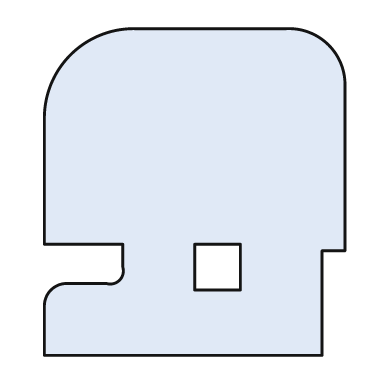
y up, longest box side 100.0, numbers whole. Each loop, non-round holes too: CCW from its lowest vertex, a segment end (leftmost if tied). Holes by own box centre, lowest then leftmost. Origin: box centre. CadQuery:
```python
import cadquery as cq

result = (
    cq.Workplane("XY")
    .moveTo(-46.0, -50.0)
    .lineTo(39.0, -50.0)
    .lineTo(39.0, -18.0)
    .lineTo(46.0, -18.0)
    .lineTo(46.0, 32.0)
    .threePointArc((41.0, 45.0), (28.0, 50.0))
    .lineTo(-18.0, 50.0)
    .threePointArc((-38.0, 42.0), (-46.0, 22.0))
    .lineTo(-46.0, -16.0)
    .lineTo(-22.0, -16.0)
    .lineTo(-22.0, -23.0)
    .threePointArc((-23.0, -27.0), (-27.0, -28.0))
    .lineTo(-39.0, -28.0)
    .threePointArc((-44.0, -30.0), (-46.0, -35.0))
    .close()
    .moveTo(0.0, -30.0)
    .lineTo(14.0, -30.0)
    .lineTo(14.0, -16.0)
    .lineTo(0.0, -16.0)
    .close()
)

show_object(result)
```